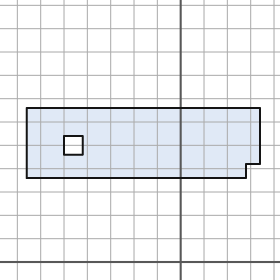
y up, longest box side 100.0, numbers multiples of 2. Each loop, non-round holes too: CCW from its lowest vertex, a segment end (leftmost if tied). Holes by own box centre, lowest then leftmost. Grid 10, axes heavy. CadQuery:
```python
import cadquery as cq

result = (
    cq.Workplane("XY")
    .moveTo(-66.0, 36.0)
    .lineTo(28.0, 36.0)
    .lineTo(28.0, 42.0)
    .lineTo(34.0, 42.0)
    .lineTo(34.0, 66.0)
    .lineTo(-66.0, 66.0)
    .close()
    .moveTo(-50.0, 46.0)
    .lineTo(-42.0, 46.0)
    .lineTo(-42.0, 54.0)
    .lineTo(-50.0, 54.0)
    .close()
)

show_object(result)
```